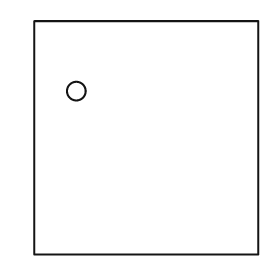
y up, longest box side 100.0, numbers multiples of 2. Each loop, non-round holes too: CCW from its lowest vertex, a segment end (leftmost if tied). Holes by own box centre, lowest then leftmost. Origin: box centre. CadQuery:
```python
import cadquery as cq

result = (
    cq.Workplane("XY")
    .moveTo(-48.0, -50.0)
    .lineTo(48.0, -50.0)
    .lineTo(48.0, 50.0)
    .lineTo(-48.0, 50.0)
    .close()
    .moveTo(-30.0, 20.0)
    .circle(4.0)
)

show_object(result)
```